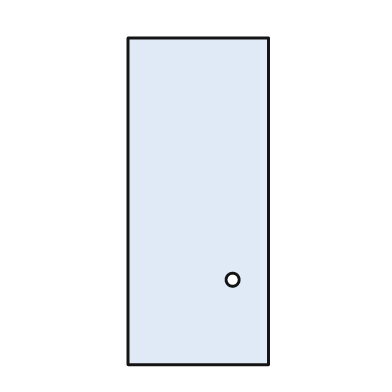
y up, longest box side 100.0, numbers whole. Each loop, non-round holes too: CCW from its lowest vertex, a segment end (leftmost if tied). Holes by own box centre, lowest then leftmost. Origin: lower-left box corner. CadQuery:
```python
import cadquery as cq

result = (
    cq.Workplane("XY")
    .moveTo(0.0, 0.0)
    .lineTo(43.0, 0.0)
    .lineTo(43.0, 100.0)
    .lineTo(0.0, 100.0)
    .close()
    .moveTo(32.0, 26.0)
    .circle(2.0)
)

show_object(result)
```